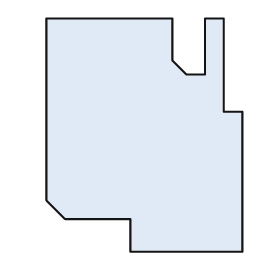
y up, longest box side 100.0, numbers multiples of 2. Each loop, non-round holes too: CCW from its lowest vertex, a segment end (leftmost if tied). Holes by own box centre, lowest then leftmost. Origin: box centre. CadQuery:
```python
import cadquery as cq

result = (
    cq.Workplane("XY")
    .moveTo(-6.0, -50.0)
    .lineTo(42.0, -50.0)
    .lineTo(42.0, 10.0)
    .lineTo(34.0, 10.0)
    .lineTo(34.0, 50.0)
    .lineTo(26.0, 50.0)
    .lineTo(26.0, 26.0)
    .lineTo(18.0, 26.0)
    .lineTo(12.0, 32.0)
    .lineTo(12.0, 50.0)
    .lineTo(-42.0, 50.0)
    .lineTo(-42.0, -28.0)
    .lineTo(-34.0, -36.0)
    .lineTo(-6.0, -36.0)
    .close()
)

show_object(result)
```